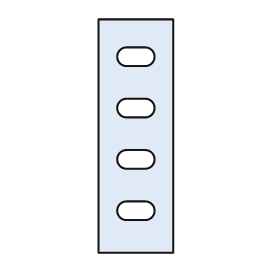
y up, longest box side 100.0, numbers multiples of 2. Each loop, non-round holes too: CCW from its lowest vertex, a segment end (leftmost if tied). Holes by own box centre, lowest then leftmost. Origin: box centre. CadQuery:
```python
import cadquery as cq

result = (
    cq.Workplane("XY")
    .moveTo(-16.0, -50.0)
    .lineTo(16.0, -50.0)
    .lineTo(16.0, 50.0)
    .lineTo(-16.0, 50.0)
    .close()
    .moveTo(-4.0, -36.0)
    .lineTo(4.0, -36.0)
    .threePointArc((8.0, -32.0), (4.0, -28.0))
    .lineTo(-4.0, -28.0)
    .threePointArc((-8.0, -32.0), (-4.0, -36.0))
    .close()
    .moveTo(-4.0, -14.0)
    .lineTo(4.0, -14.0)
    .threePointArc((8.0, -10.0), (4.0, -6.0))
    .lineTo(-4.0, -6.0)
    .threePointArc((-8.0, -10.0), (-4.0, -14.0))
    .close()
    .moveTo(-4.0, 8.0)
    .lineTo(4.0, 8.0)
    .threePointArc((8.0, 12.0), (4.0, 16.0))
    .lineTo(-4.0, 16.0)
    .threePointArc((-8.0, 12.0), (-4.0, 8.0))
    .close()
    .moveTo(-4.0, 30.0)
    .lineTo(4.0, 30.0)
    .threePointArc((8.0, 34.0), (4.0, 38.0))
    .lineTo(-4.0, 38.0)
    .threePointArc((-8.0, 34.0), (-4.0, 30.0))
    .close()
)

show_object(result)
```